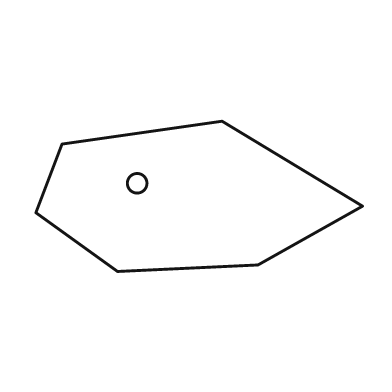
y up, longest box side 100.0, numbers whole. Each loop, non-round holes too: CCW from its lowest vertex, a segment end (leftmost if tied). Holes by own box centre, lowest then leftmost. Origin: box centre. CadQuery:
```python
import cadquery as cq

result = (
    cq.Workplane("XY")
    .moveTo(-25.0, -23.0)
    .lineTo(18.0, -21.0)
    .lineTo(50.0, -3.0)
    .lineTo(7.0, 23.0)
    .lineTo(-42.0, 16.0)
    .lineTo(-50.0, -5.0)
    .close()
    .moveTo(-19.0, 4.0)
    .circle(3.0)
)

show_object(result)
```